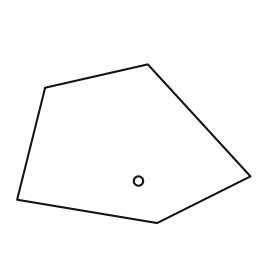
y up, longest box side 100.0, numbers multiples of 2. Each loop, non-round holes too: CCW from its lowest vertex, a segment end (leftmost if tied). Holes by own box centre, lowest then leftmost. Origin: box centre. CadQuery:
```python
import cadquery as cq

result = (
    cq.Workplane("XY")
    .moveTo(10.0, -34.0)
    .lineTo(50.0, -14.0)
    .lineTo(6.0, 34.0)
    .lineTo(-38.0, 24.0)
    .lineTo(-50.0, -24.0)
    .close()
    .moveTo(2.0, -16.0)
    .circle(2.0)
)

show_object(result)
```